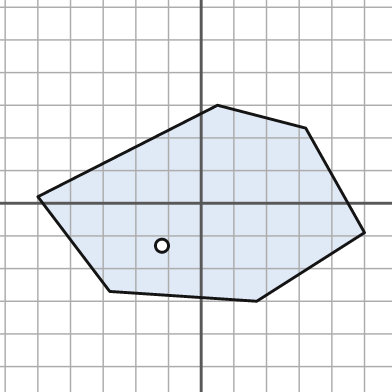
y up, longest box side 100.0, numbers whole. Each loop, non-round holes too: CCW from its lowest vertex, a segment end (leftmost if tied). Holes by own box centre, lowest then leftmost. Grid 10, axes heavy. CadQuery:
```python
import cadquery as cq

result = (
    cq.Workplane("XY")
    .moveTo(17.0, -30.0)
    .lineTo(50.0, -9.0)
    .lineTo(32.0, 23.0)
    .lineTo(5.0, 30.0)
    .lineTo(-50.0, 2.0)
    .lineTo(-28.0, -27.0)
    .close()
    .moveTo(-12.0, -13.0)
    .circle(2.0)
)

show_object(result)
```